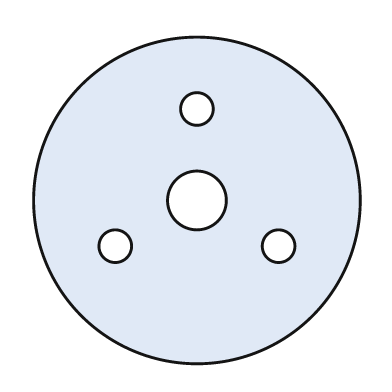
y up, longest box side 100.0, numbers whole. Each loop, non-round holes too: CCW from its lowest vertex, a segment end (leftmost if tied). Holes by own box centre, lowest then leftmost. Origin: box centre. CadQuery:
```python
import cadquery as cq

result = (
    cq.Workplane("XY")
    .moveTo(0.0, 0.0)
    .circle(50.0)
    .moveTo(-25.0, -14.0)
    .circle(5.0)
    .moveTo(25.0, -14.0)
    .circle(5.0)
    .moveTo(0.0, 0.0)
    .circle(9.0)
    .moveTo(0.0, 28.0)
    .circle(5.0)
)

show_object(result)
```